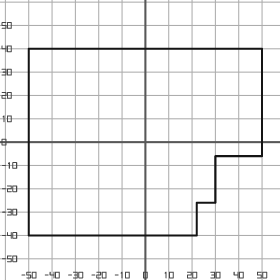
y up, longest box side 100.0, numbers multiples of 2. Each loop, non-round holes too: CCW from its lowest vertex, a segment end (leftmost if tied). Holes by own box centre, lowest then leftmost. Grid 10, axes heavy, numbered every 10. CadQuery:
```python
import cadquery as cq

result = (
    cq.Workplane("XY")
    .moveTo(-50.0, -40.0)
    .lineTo(22.0, -40.0)
    .lineTo(22.0, -26.0)
    .lineTo(30.0, -26.0)
    .lineTo(30.0, -6.0)
    .lineTo(50.0, -6.0)
    .lineTo(50.0, 40.0)
    .lineTo(-50.0, 40.0)
    .close()
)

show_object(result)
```